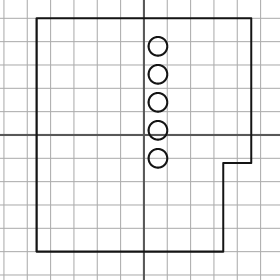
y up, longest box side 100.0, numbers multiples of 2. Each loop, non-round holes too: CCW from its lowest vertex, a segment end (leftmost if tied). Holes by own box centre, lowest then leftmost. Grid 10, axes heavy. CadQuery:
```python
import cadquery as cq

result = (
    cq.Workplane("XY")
    .moveTo(-46.0, -50.0)
    .lineTo(34.0, -50.0)
    .lineTo(34.0, -12.0)
    .lineTo(46.0, -12.0)
    .lineTo(46.0, 50.0)
    .lineTo(-46.0, 50.0)
    .close()
    .moveTo(6.0, -10.0)
    .circle(4.0)
    .moveTo(6.0, 2.0)
    .circle(4.0)
    .moveTo(6.0, 14.0)
    .circle(4.0)
    .moveTo(6.0, 26.0)
    .circle(4.0)
    .moveTo(6.0, 38.0)
    .circle(4.0)
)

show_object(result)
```